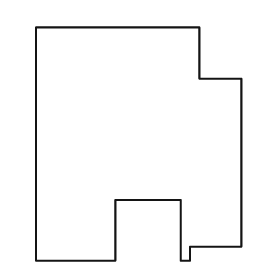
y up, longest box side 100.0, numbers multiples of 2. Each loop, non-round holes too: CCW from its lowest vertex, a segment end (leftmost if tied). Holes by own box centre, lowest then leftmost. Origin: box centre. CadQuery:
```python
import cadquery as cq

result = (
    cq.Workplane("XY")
    .moveTo(-44.0, -50.0)
    .lineTo(-10.0, -50.0)
    .lineTo(-10.0, -24.0)
    .lineTo(18.0, -24.0)
    .lineTo(18.0, -50.0)
    .lineTo(22.0, -50.0)
    .lineTo(22.0, -44.0)
    .lineTo(44.0, -44.0)
    .lineTo(44.0, 28.0)
    .lineTo(26.0, 28.0)
    .lineTo(26.0, 50.0)
    .lineTo(-44.0, 50.0)
    .close()
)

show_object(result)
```